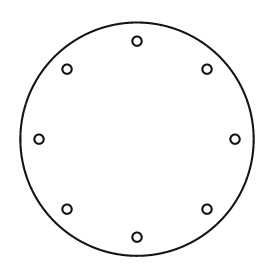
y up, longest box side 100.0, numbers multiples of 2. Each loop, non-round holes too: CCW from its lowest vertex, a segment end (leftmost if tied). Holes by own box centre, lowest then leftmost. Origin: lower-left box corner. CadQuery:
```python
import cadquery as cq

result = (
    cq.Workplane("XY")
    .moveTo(50.0, 50.0)
    .circle(50.0)
    .moveTo(50.0, 8.0)
    .circle(2.0)
    .moveTo(20.0, 20.0)
    .circle(2.0)
    .moveTo(80.0, 20.0)
    .circle(2.0)
    .moveTo(8.0, 50.0)
    .circle(2.0)
    .moveTo(92.0, 50.0)
    .circle(2.0)
    .moveTo(20.0, 80.0)
    .circle(2.0)
    .moveTo(80.0, 80.0)
    .circle(2.0)
    .moveTo(50.0, 92.0)
    .circle(2.0)
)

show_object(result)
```